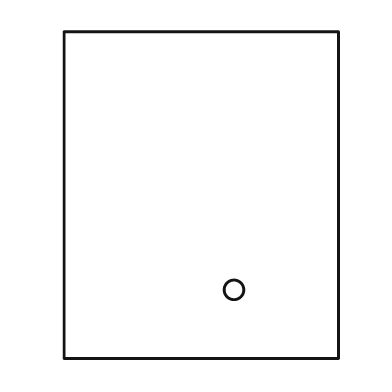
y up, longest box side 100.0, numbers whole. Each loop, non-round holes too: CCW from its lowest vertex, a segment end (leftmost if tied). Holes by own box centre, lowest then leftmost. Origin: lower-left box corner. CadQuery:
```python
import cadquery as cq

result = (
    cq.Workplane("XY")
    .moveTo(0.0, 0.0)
    .lineTo(84.0, 0.0)
    .lineTo(84.0, 100.0)
    .lineTo(0.0, 100.0)
    .close()
    .moveTo(52.0, 21.0)
    .circle(3.0)
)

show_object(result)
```